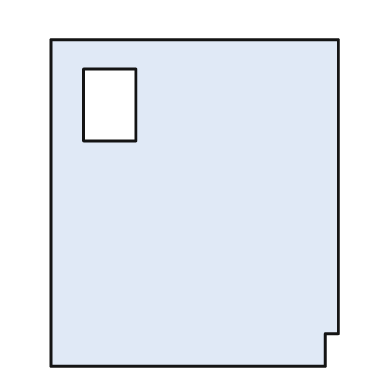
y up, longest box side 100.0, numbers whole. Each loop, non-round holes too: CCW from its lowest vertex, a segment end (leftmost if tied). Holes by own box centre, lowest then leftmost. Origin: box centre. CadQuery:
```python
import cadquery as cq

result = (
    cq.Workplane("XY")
    .moveTo(-44.0, -50.0)
    .lineTo(40.0, -50.0)
    .lineTo(40.0, -40.0)
    .lineTo(44.0, -40.0)
    .lineTo(44.0, 50.0)
    .lineTo(-44.0, 50.0)
    .close()
    .moveTo(-34.0, 19.0)
    .lineTo(-18.0, 19.0)
    .lineTo(-18.0, 41.0)
    .lineTo(-34.0, 41.0)
    .close()
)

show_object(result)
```